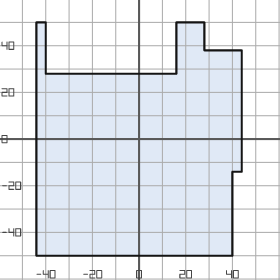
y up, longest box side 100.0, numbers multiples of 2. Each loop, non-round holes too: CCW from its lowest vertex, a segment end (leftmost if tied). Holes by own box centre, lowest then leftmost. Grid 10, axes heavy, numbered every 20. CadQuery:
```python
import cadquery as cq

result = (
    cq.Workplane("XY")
    .moveTo(-44.0, -50.0)
    .lineTo(40.0, -50.0)
    .lineTo(40.0, -14.0)
    .lineTo(44.0, -14.0)
    .lineTo(44.0, 38.0)
    .lineTo(28.0, 38.0)
    .lineTo(28.0, 50.0)
    .lineTo(16.0, 50.0)
    .lineTo(16.0, 28.0)
    .lineTo(-40.0, 28.0)
    .lineTo(-40.0, 50.0)
    .lineTo(-44.0, 50.0)
    .close()
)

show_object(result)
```